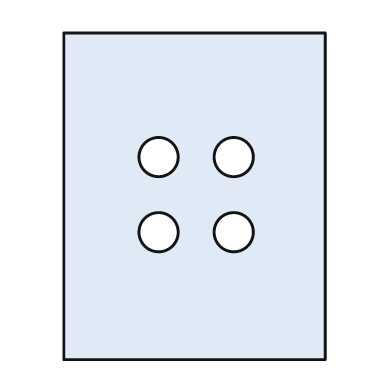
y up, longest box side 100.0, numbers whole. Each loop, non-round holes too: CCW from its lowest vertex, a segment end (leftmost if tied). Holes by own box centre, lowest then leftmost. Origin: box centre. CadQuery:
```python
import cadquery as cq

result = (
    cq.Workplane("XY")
    .moveTo(-40.0, -50.0)
    .lineTo(40.0, -50.0)
    .lineTo(40.0, 50.0)
    .lineTo(-40.0, 50.0)
    .close()
    .moveTo(-11.0, -11.0)
    .circle(6.0)
    .moveTo(12.0, -11.0)
    .circle(6.0)
    .moveTo(-11.0, 12.0)
    .circle(6.0)
    .moveTo(12.0, 12.0)
    .circle(6.0)
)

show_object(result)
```